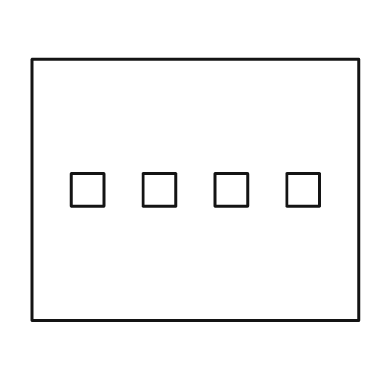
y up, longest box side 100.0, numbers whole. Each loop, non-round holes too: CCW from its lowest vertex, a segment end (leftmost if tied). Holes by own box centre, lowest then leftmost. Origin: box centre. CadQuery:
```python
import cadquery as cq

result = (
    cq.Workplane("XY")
    .moveTo(-50.0, -40.0)
    .lineTo(50.0, -40.0)
    .lineTo(50.0, 40.0)
    .lineTo(-50.0, 40.0)
    .close()
    .moveTo(-38.0, -5.0)
    .lineTo(-28.0, -5.0)
    .lineTo(-28.0, 5.0)
    .lineTo(-38.0, 5.0)
    .close()
    .moveTo(-16.0, -5.0)
    .lineTo(-6.0, -5.0)
    .lineTo(-6.0, 5.0)
    .lineTo(-16.0, 5.0)
    .close()
    .moveTo(6.0, -5.0)
    .lineTo(16.0, -5.0)
    .lineTo(16.0, 5.0)
    .lineTo(6.0, 5.0)
    .close()
    .moveTo(28.0, -5.0)
    .lineTo(38.0, -5.0)
    .lineTo(38.0, 5.0)
    .lineTo(28.0, 5.0)
    .close()
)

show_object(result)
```